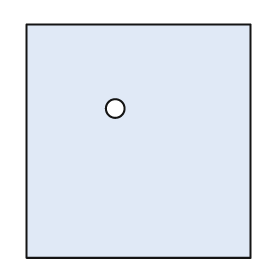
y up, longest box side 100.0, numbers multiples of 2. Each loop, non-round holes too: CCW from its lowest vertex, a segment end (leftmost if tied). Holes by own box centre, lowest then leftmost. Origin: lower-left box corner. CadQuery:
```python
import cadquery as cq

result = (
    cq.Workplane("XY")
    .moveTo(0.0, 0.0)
    .lineTo(96.0, 0.0)
    .lineTo(96.0, 100.0)
    .lineTo(0.0, 100.0)
    .close()
    .moveTo(38.0, 64.0)
    .circle(4.0)
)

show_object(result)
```